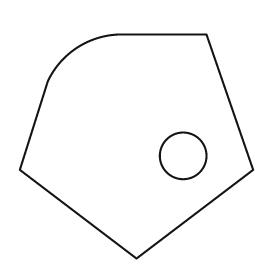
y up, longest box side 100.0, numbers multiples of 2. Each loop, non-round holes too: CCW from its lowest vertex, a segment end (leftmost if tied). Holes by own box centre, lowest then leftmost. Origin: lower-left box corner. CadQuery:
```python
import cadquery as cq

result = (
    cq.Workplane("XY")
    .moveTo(50.0, 0.0)
    .lineTo(100.0, 38.0)
    .lineTo(80.0, 96.0)
    .lineTo(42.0, 96.0)
    .threePointArc((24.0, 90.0), (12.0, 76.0))
    .lineTo(0.0, 38.0)
    .close()
    .moveTo(70.0, 44.0)
    .circle(10.0)
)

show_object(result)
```